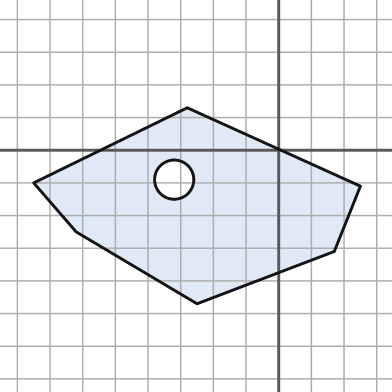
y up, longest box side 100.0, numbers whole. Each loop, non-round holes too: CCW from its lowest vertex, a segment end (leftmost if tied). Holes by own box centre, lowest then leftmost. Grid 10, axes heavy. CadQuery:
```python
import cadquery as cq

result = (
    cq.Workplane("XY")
    .moveTo(-25.0, -47.0)
    .lineTo(17.0, -31.0)
    .lineTo(25.0, -11.0)
    .lineTo(-28.0, 13.0)
    .lineTo(-75.0, -10.0)
    .lineTo(-62.0, -25.0)
    .close()
    .moveTo(-32.0, -9.0)
    .circle(6.0)
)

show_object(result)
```